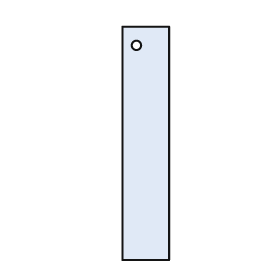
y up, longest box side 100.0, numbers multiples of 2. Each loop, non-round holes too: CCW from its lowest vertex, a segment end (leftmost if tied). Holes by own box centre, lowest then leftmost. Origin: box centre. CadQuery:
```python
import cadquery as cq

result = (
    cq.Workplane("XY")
    .moveTo(-10.0, -50.0)
    .lineTo(10.0, -50.0)
    .lineTo(10.0, 50.0)
    .lineTo(-10.0, 50.0)
    .close()
    .moveTo(-4.0, 42.0)
    .circle(2.0)
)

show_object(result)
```